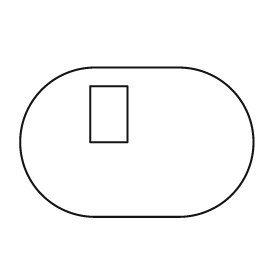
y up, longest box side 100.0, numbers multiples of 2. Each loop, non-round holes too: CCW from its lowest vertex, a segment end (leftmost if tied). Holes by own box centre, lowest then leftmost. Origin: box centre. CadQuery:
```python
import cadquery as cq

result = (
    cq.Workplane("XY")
    .moveTo(-18.0, -32.0)
    .lineTo(18.0, -32.0)
    .threePointArc((50.0, 0.0), (18.0, 32.0))
    .lineTo(-18.0, 32.0)
    .threePointArc((-50.0, 0.0), (-18.0, -32.0))
    .close()
    .moveTo(-20.0, 0.0)
    .lineTo(-4.0, 0.0)
    .lineTo(-4.0, 24.0)
    .lineTo(-20.0, 24.0)
    .close()
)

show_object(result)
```